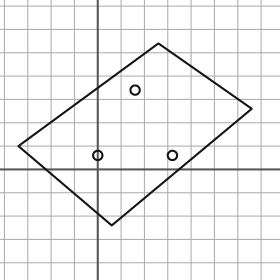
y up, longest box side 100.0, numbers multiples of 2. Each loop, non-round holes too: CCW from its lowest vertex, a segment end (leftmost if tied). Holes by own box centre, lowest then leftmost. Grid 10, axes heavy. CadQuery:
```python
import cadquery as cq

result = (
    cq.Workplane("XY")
    .moveTo(6.0, -24.0)
    .lineTo(66.0, 26.0)
    .lineTo(26.0, 54.0)
    .lineTo(-34.0, 10.0)
    .close()
    .moveTo(0.0, 6.0)
    .circle(2.0)
    .moveTo(32.0, 6.0)
    .circle(2.0)
    .moveTo(16.0, 34.0)
    .circle(2.0)
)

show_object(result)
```